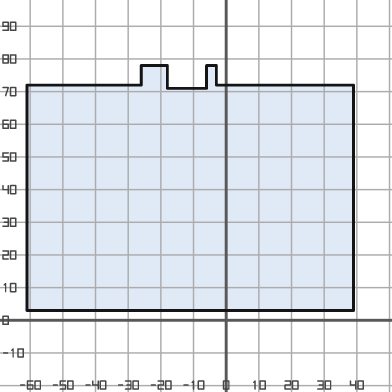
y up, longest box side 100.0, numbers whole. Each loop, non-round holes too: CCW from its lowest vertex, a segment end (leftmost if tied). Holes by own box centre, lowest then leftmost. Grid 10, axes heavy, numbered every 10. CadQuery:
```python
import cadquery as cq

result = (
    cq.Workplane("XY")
    .moveTo(-61.0, 3.0)
    .lineTo(39.0, 3.0)
    .lineTo(39.0, 72.0)
    .lineTo(-3.0, 72.0)
    .lineTo(-3.0, 78.0)
    .lineTo(-6.0, 78.0)
    .lineTo(-6.0, 71.0)
    .lineTo(-18.0, 71.0)
    .lineTo(-18.0, 78.0)
    .lineTo(-26.0, 78.0)
    .lineTo(-26.0, 72.0)
    .lineTo(-61.0, 72.0)
    .close()
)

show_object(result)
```